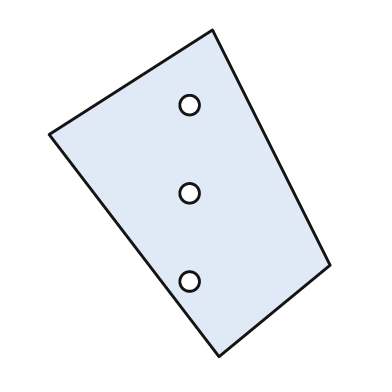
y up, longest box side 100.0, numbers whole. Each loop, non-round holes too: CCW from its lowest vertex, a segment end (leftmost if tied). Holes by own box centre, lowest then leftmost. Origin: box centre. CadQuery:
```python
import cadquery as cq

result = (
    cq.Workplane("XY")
    .moveTo(9.0, -50.0)
    .lineTo(43.0, -22.0)
    .lineTo(7.0, 50.0)
    .lineTo(-43.0, 18.0)
    .close()
    .moveTo(0.0, -27.0)
    .circle(3.0)
    .moveTo(0.0, 0.0)
    .circle(3.0)
    .moveTo(0.0, 27.0)
    .circle(3.0)
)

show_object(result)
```